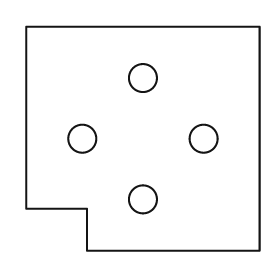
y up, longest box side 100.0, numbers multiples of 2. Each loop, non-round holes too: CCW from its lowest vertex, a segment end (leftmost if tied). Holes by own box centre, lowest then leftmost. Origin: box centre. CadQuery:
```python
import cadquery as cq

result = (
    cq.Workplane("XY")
    .moveTo(-24.0, -48.0)
    .lineTo(50.0, -48.0)
    .lineTo(50.0, 48.0)
    .lineTo(-50.0, 48.0)
    .lineTo(-50.0, -30.0)
    .lineTo(-24.0, -30.0)
    .close()
    .moveTo(0.0, -26.0)
    .circle(6.0)
    .moveTo(-26.0, 0.0)
    .circle(6.0)
    .moveTo(26.0, 0.0)
    .circle(6.0)
    .moveTo(0.0, 26.0)
    .circle(6.0)
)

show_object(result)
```